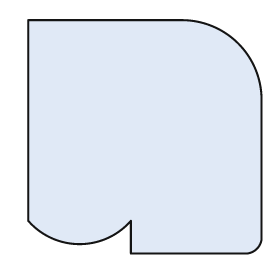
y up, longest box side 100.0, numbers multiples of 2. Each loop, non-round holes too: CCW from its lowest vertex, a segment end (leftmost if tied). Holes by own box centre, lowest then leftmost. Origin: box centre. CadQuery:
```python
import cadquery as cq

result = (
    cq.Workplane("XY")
    .moveTo(-6.0, -50.0)
    .lineTo(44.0, -50.0)
    .threePointArc((48.0, -48.0), (50.0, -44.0))
    .lineTo(50.0, 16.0)
    .threePointArc((40.0, 40.0), (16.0, 50.0))
    .lineTo(-50.0, 50.0)
    .lineTo(-50.0, -36.0)
    .threePointArc((-28.0, -46.0), (-6.0, -36.0))
    .close()
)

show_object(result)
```